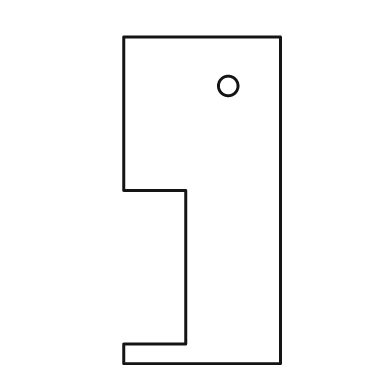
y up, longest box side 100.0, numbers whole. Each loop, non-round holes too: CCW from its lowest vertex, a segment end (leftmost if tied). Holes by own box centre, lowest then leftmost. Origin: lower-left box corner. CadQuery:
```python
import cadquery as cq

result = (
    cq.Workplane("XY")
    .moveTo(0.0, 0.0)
    .lineTo(48.0, 0.0)
    .lineTo(48.0, 100.0)
    .lineTo(0.0, 100.0)
    .lineTo(0.0, 53.0)
    .lineTo(19.0, 53.0)
    .lineTo(19.0, 6.0)
    .lineTo(0.0, 6.0)
    .close()
    .moveTo(32.0, 85.0)
    .circle(3.0)
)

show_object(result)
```